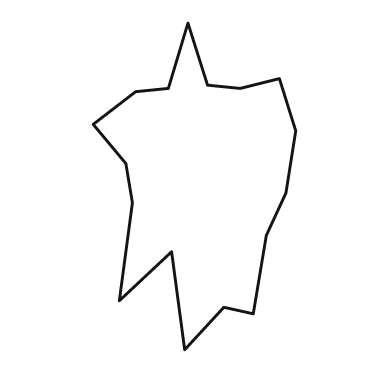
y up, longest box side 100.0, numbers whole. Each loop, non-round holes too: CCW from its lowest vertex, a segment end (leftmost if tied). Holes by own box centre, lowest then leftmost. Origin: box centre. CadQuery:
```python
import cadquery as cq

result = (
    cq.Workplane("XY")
    .moveTo(-3.0, -50.0)
    .lineTo(9.0, -37.0)
    .lineTo(18.0, -39.0)
    .lineTo(22.0, -15.0)
    .lineTo(28.0, -2.0)
    .lineTo(31.0, 17.0)
    .lineTo(26.0, 33.0)
    .lineTo(14.0, 30.0)
    .lineTo(4.0, 31.0)
    .lineTo(-2.0, 50.0)
    .lineTo(-8.0, 30.0)
    .lineTo(-18.0, 29.0)
    .lineTo(-31.0, 19.0)
    .lineTo(-21.0, 7.0)
    .lineTo(-19.0, -5.0)
    .lineTo(-23.0, -35.0)
    .lineTo(-7.0, -20.0)
    .close()
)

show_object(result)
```